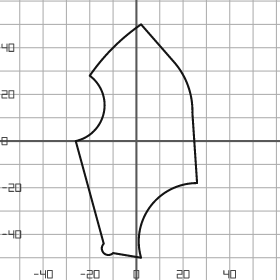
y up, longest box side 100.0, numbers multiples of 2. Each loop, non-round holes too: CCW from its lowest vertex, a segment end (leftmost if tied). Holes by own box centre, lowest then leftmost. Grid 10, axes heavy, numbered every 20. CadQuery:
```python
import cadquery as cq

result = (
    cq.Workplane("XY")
    .moveTo(2.0, -50.0)
    .threePointArc((6.0, -28.0), (26.0, -18.0))
    .lineTo(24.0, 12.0)
    .threePointArc((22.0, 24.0), (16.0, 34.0))
    .lineTo(2.0, 50.0)
    .threePointArc((-10.0, 40.0), (-20.0, 28.0))
    .threePointArc((-14.0, 12.0), (-26.0, 0.0))
    .lineTo(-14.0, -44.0)
    .threePointArc((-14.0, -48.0), (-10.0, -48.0))
    .close()
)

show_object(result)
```